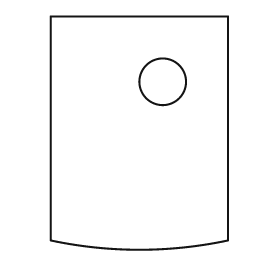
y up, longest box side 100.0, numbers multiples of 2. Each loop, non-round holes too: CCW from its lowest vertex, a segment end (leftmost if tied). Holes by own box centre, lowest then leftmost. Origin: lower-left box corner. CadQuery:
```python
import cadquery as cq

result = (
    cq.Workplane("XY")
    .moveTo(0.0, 4.0)
    .threePointArc((38.0, 0.0), (76.0, 4.0))
    .lineTo(76.0, 100.0)
    .lineTo(0.0, 100.0)
    .close()
    .moveTo(48.0, 72.0)
    .circle(10.0)
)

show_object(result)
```